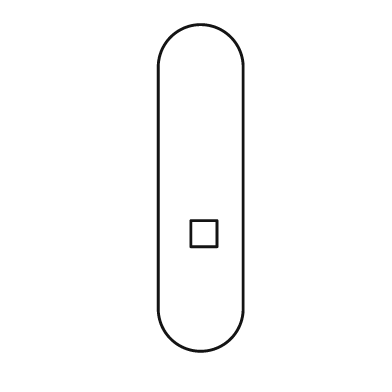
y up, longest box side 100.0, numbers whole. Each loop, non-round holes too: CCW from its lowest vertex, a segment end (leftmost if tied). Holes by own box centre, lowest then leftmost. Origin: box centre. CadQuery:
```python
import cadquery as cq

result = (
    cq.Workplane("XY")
    .moveTo(-13.0, -37.0)
    .threePointArc((0.0, -50.0), (13.0, -37.0))
    .lineTo(13.0, 37.0)
    .threePointArc((0.0, 50.0), (-13.0, 37.0))
    .close()
    .moveTo(-3.0, -18.0)
    .lineTo(5.0, -18.0)
    .lineTo(5.0, -10.0)
    .lineTo(-3.0, -10.0)
    .close()
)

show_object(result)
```